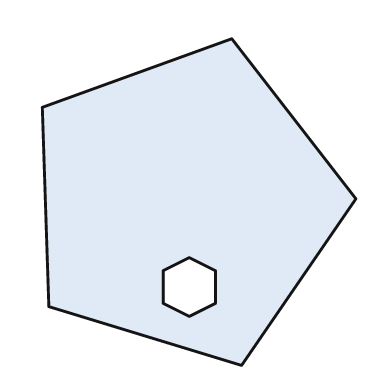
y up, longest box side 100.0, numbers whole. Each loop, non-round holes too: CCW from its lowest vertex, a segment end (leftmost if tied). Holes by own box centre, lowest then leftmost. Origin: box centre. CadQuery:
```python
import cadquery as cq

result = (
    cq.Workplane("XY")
    .moveTo(13.0, -50.0)
    .lineTo(48.0, 1.0)
    .lineTo(10.0, 50.0)
    .lineTo(-48.0, 29.0)
    .lineTo(-46.0, -32.0)
    .close()
    .moveTo(-3.0, -35.0)
    .lineTo(5.0, -31.0)
    .lineTo(5.0, -21.0)
    .lineTo(-3.0, -17.0)
    .lineTo(-11.0, -21.0)
    .lineTo(-11.0, -31.0)
    .close()
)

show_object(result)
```